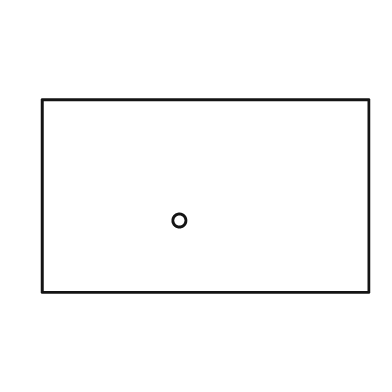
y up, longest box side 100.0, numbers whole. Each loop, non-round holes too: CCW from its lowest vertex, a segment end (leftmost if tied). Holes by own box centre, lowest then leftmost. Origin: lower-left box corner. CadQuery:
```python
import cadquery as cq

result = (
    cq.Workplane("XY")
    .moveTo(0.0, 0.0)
    .lineTo(100.0, 0.0)
    .lineTo(100.0, 59.0)
    .lineTo(0.0, 59.0)
    .close()
    .moveTo(42.0, 22.0)
    .circle(2.0)
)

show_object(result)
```